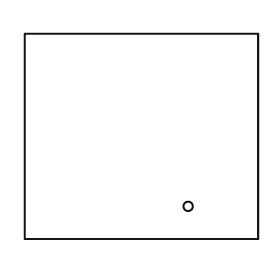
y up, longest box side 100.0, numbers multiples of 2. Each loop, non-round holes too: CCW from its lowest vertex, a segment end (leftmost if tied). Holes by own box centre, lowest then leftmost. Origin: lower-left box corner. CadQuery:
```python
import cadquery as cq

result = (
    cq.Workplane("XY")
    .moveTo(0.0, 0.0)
    .lineTo(100.0, 0.0)
    .lineTo(100.0, 88.0)
    .lineTo(0.0, 88.0)
    .close()
    .moveTo(70.0, 14.0)
    .circle(2.0)
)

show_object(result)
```